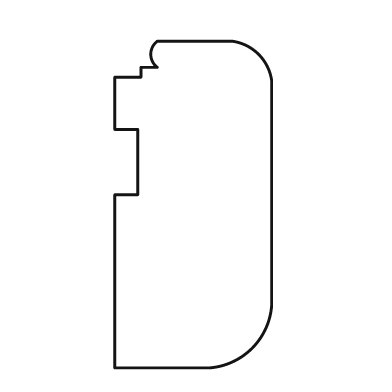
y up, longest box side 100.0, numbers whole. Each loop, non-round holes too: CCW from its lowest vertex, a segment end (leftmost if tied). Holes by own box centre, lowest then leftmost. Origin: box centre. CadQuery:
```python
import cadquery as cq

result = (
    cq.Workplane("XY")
    .moveTo(-24.0, -50.0)
    .lineTo(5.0, -50.0)
    .threePointArc((18.0, -44.0), (24.0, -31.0))
    .lineTo(24.0, 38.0)
    .threePointArc((20.0, 46.0), (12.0, 50.0))
    .lineTo(-11.0, 50.0)
    .threePointArc((-13.0, 46.0), (-11.0, 42.0))
    .lineTo(-16.0, 42.0)
    .lineTo(-16.0, 39.0)
    .lineTo(-24.0, 39.0)
    .lineTo(-24.0, 23.0)
    .lineTo(-17.0, 23.0)
    .lineTo(-17.0, 3.0)
    .lineTo(-24.0, 3.0)
    .close()
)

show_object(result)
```